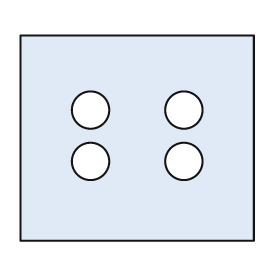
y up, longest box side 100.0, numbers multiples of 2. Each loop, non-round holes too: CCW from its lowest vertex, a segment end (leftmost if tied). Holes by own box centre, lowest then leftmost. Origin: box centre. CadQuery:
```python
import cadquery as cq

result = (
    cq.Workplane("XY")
    .moveTo(-50.0, -44.0)
    .lineTo(50.0, -44.0)
    .lineTo(50.0, 44.0)
    .lineTo(-50.0, 44.0)
    .close()
    .moveTo(-20.0, -10.0)
    .circle(8.0)
    .moveTo(20.0, -10.0)
    .circle(8.0)
    .moveTo(-20.0, 12.0)
    .circle(8.0)
    .moveTo(20.0, 12.0)
    .circle(8.0)
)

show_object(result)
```